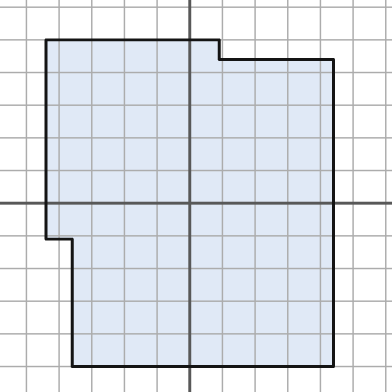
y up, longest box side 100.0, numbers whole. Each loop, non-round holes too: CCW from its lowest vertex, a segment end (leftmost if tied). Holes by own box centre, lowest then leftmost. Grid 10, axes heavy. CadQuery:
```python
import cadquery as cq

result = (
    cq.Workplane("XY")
    .moveTo(-36.0, -50.0)
    .lineTo(44.0, -50.0)
    .lineTo(44.0, 44.0)
    .lineTo(9.0, 44.0)
    .lineTo(9.0, 50.0)
    .lineTo(-44.0, 50.0)
    .lineTo(-44.0, -11.0)
    .lineTo(-36.0, -11.0)
    .close()
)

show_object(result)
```